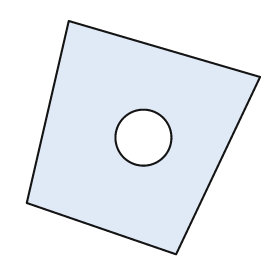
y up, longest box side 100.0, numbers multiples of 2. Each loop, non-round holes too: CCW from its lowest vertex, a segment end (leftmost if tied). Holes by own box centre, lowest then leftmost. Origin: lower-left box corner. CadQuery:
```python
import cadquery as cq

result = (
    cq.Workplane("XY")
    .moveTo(64.0, 0.0)
    .lineTo(100.0, 76.0)
    .lineTo(18.0, 100.0)
    .lineTo(0.0, 22.0)
    .close()
    .moveTo(50.0, 50.0)
    .circle(12.0)
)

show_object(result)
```